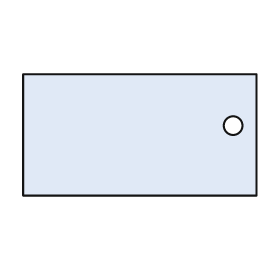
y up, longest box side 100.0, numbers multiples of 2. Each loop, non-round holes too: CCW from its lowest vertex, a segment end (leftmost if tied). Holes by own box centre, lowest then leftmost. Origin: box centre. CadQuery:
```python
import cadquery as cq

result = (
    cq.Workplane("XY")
    .moveTo(-50.0, -26.0)
    .lineTo(50.0, -26.0)
    .lineTo(50.0, 26.0)
    .lineTo(-50.0, 26.0)
    .close()
    .moveTo(40.0, 4.0)
    .circle(4.0)
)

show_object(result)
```